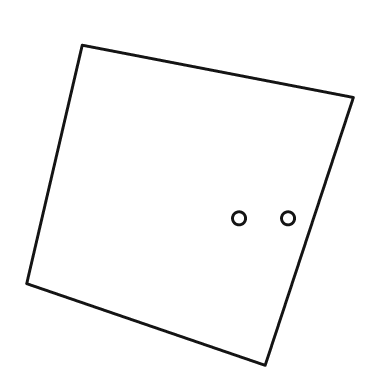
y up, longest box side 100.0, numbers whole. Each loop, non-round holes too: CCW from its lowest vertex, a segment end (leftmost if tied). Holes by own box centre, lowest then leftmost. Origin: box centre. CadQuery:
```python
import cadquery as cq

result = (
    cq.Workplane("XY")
    .moveTo(23.0, -49.0)
    .lineTo(50.0, 33.0)
    .lineTo(-33.0, 49.0)
    .lineTo(-50.0, -24.0)
    .close()
    .moveTo(15.0, -4.0)
    .circle(2.0)
    .moveTo(30.0, -4.0)
    .circle(2.0)
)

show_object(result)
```